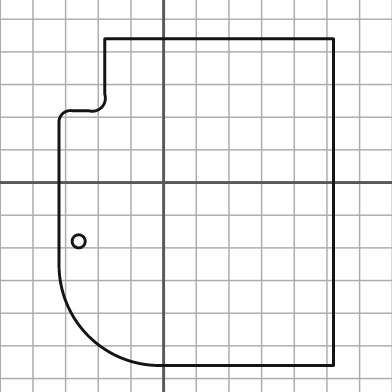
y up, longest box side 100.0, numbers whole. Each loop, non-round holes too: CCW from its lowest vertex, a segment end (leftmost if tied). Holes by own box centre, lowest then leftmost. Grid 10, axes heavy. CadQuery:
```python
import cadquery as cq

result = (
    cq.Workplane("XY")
    .moveTo(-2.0, -56.0)
    .lineTo(52.0, -56.0)
    .lineTo(52.0, 44.0)
    .lineTo(-18.0, 44.0)
    .lineTo(-18.0, 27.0)
    .threePointArc((-19.0, 23.0), (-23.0, 22.0))
    .lineTo(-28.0, 22.0)
    .threePointArc((-31.0, 21.0), (-32.0, 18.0))
    .lineTo(-32.0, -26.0)
    .threePointArc((-23.0, -47.0), (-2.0, -56.0))
    .close()
    .moveTo(-26.0, -18.0)
    .circle(2.0)
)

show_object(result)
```